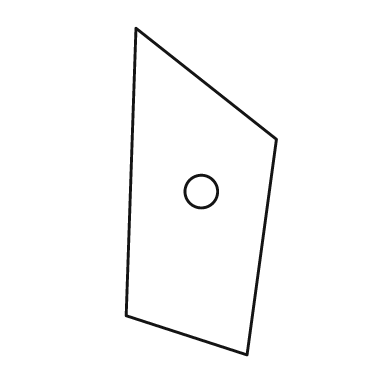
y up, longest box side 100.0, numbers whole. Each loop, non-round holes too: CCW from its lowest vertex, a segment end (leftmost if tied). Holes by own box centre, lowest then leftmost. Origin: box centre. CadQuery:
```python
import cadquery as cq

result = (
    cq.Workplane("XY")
    .moveTo(14.0, -50.0)
    .lineTo(23.0, 16.0)
    .lineTo(-20.0, 50.0)
    .lineTo(-23.0, -38.0)
    .close()
    .moveTo(0.0, 0.0)
    .circle(5.0)
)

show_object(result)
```